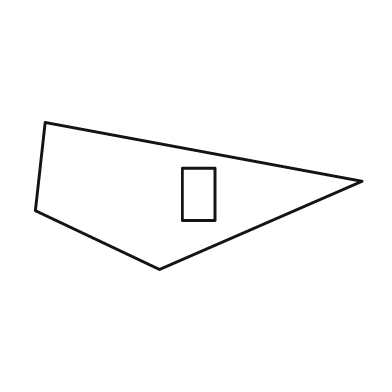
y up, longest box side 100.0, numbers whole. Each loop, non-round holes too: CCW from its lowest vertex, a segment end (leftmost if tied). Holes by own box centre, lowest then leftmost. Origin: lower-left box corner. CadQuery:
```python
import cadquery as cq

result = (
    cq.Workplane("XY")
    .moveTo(38.0, 0.0)
    .lineTo(100.0, 27.0)
    .lineTo(3.0, 45.0)
    .lineTo(0.0, 18.0)
    .close()
    .moveTo(45.0, 15.0)
    .lineTo(55.0, 15.0)
    .lineTo(55.0, 31.0)
    .lineTo(45.0, 31.0)
    .close()
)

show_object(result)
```